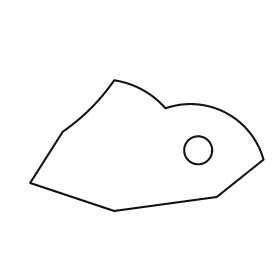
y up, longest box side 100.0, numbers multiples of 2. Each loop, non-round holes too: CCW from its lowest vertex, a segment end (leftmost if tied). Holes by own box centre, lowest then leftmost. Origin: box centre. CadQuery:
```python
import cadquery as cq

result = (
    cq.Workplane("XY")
    .moveTo(-14.0, -28.0)
    .lineTo(30.0, -22.0)
    .lineTo(50.0, -6.0)
    .threePointArc((34.0, 14.0), (8.0, 16.0))
    .threePointArc((-2.0, 24.0), (-14.0, 28.0))
    .threePointArc((-24.0, 16.0), (-36.0, 6.0))
    .lineTo(-50.0, -16.0)
    .close()
    .moveTo(22.0, -2.0)
    .circle(6.0)
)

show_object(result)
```